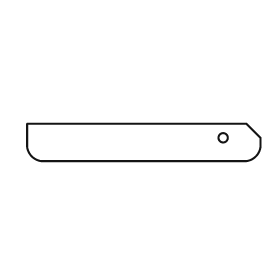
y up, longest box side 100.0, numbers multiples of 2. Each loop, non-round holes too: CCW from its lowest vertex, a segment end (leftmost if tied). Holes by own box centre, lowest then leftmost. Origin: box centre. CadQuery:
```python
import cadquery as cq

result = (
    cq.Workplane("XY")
    .moveTo(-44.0, -8.0)
    .lineTo(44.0, -8.0)
    .threePointArc((48.0, -6.0), (50.0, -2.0))
    .lineTo(50.0, 2.0)
    .lineTo(44.0, 8.0)
    .lineTo(-50.0, 8.0)
    .lineTo(-50.0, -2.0)
    .threePointArc((-48.0, -6.0), (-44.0, -8.0))
    .close()
    .moveTo(34.0, 2.0)
    .circle(2.0)
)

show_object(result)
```